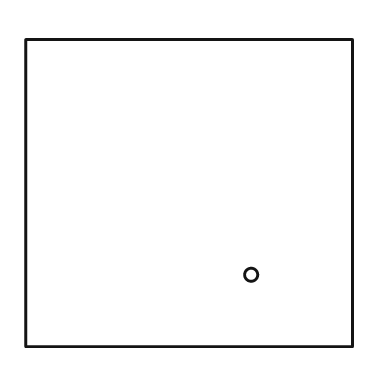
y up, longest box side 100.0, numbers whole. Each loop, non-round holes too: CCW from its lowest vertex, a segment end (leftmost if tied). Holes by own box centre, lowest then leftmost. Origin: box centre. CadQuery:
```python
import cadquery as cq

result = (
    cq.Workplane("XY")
    .moveTo(-50.0, -47.0)
    .lineTo(50.0, -47.0)
    .lineTo(50.0, 47.0)
    .lineTo(-50.0, 47.0)
    .close()
    .moveTo(19.0, -25.0)
    .circle(2.0)
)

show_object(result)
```